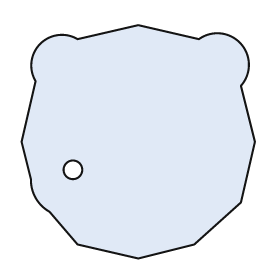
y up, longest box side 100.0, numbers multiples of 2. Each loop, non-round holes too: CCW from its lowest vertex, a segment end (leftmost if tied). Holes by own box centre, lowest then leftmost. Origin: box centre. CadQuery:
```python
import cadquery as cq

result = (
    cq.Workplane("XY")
    .moveTo(0.0, -50.0)
    .lineTo(24.0, -44.0)
    .lineTo(44.0, -26.0)
    .lineTo(50.0, 0.0)
    .lineTo(44.0, 24.0)
    .threePointArc((44.0, 42.0), (26.0, 44.0))
    .lineTo(0.0, 50.0)
    .lineTo(-26.0, 44.0)
    .threePointArc((-42.0, 42.0), (-44.0, 26.0))
    .lineTo(-50.0, 0.0)
    .lineTo(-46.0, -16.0)
    .threePointArc((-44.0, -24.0), (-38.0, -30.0))
    .lineTo(-26.0, -44.0)
    .close()
    .moveTo(-28.0, -12.0)
    .circle(4.0)
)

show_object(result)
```